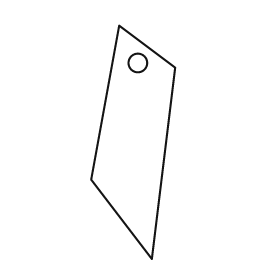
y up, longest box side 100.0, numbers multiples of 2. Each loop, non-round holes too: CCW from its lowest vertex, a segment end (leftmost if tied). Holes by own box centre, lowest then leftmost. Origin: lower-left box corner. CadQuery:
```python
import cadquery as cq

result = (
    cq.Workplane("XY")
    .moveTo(26.0, 0.0)
    .lineTo(36.0, 82.0)
    .lineTo(12.0, 100.0)
    .lineTo(0.0, 34.0)
    .close()
    .moveTo(20.0, 84.0)
    .circle(4.0)
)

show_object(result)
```